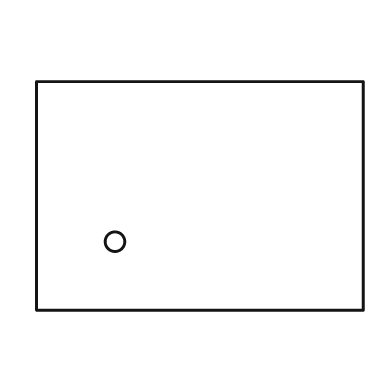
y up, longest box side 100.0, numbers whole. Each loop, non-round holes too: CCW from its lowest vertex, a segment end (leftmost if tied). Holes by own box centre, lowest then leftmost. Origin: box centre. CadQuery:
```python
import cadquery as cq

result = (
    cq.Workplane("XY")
    .moveTo(-50.0, -35.0)
    .lineTo(50.0, -35.0)
    .lineTo(50.0, 35.0)
    .lineTo(-50.0, 35.0)
    .close()
    .moveTo(-26.0, -14.0)
    .circle(3.0)
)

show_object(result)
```